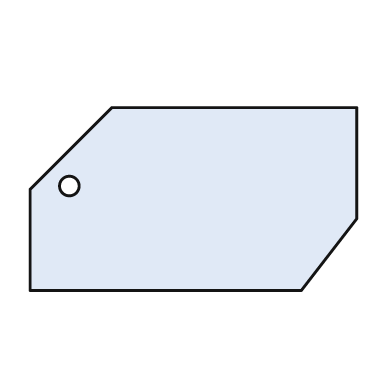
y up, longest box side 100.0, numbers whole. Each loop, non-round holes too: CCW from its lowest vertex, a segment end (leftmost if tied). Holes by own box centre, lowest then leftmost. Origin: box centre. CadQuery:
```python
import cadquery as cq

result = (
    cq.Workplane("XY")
    .moveTo(-50.0, -28.0)
    .lineTo(33.0, -28.0)
    .lineTo(50.0, -6.0)
    .lineTo(50.0, 28.0)
    .lineTo(-25.0, 28.0)
    .lineTo(-50.0, 3.0)
    .close()
    .moveTo(-38.0, 4.0)
    .circle(3.0)
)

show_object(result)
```